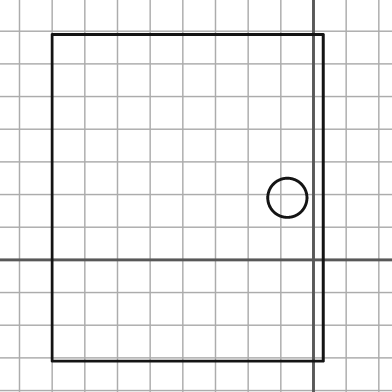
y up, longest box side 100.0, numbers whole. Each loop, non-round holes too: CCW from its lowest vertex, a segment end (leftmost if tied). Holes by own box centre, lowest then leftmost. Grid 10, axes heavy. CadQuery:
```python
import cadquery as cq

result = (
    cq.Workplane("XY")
    .moveTo(-80.0, -31.0)
    .lineTo(3.0, -31.0)
    .lineTo(3.0, 69.0)
    .lineTo(-80.0, 69.0)
    .close()
    .moveTo(-8.0, 19.0)
    .circle(6.0)
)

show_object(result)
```